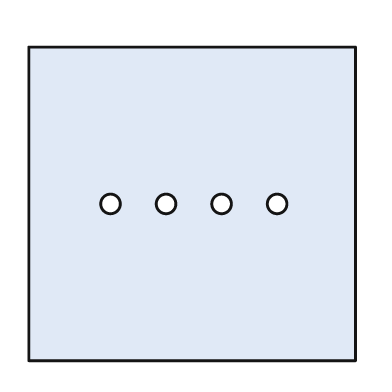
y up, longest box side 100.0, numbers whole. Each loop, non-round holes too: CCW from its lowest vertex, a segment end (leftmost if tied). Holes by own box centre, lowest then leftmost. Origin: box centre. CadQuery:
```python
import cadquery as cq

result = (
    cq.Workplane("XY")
    .moveTo(-50.0, -48.0)
    .lineTo(50.0, -48.0)
    .lineTo(50.0, 48.0)
    .lineTo(-50.0, 48.0)
    .close()
    .moveTo(-25.0, 0.0)
    .circle(3.0)
    .moveTo(-8.0, 0.0)
    .circle(3.0)
    .moveTo(9.0, 0.0)
    .circle(3.0)
    .moveTo(26.0, 0.0)
    .circle(3.0)
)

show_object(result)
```